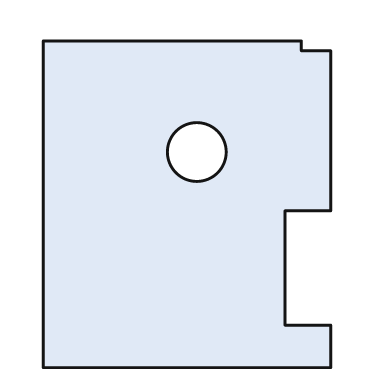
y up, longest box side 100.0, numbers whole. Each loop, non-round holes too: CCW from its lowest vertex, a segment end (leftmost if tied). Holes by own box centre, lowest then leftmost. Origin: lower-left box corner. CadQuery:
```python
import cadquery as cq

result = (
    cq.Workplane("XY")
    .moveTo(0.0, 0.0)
    .lineTo(88.0, 0.0)
    .lineTo(88.0, 13.0)
    .lineTo(74.0, 13.0)
    .lineTo(74.0, 48.0)
    .lineTo(88.0, 48.0)
    .lineTo(88.0, 97.0)
    .lineTo(79.0, 97.0)
    .lineTo(79.0, 100.0)
    .lineTo(0.0, 100.0)
    .close()
    .moveTo(47.0, 66.0)
    .circle(9.0)
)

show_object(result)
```